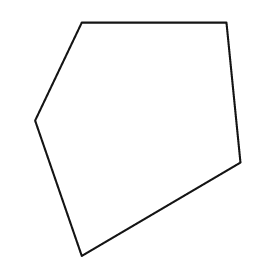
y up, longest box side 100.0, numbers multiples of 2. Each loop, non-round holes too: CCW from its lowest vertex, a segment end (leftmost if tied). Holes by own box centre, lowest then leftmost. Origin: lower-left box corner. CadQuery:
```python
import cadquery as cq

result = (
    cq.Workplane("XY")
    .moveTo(20.0, 0.0)
    .lineTo(88.0, 40.0)
    .lineTo(82.0, 100.0)
    .lineTo(20.0, 100.0)
    .lineTo(0.0, 58.0)
    .close()
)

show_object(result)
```